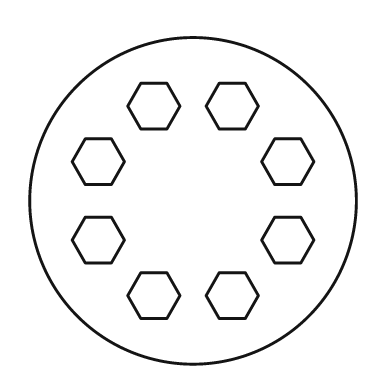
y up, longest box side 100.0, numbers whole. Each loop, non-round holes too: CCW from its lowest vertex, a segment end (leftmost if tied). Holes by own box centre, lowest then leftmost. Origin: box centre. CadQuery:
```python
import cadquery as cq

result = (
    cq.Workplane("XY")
    .moveTo(0.0, 0.0)
    .circle(50.0)
    .moveTo(-16.0, -36.0)
    .lineTo(-8.0, -36.0)
    .lineTo(-4.0, -29.0)
    .lineTo(-8.0, -22.0)
    .lineTo(-16.0, -22.0)
    .lineTo(-20.0, -29.0)
    .close()
    .moveTo(8.0, -36.0)
    .lineTo(16.0, -36.0)
    .lineTo(20.0, -29.0)
    .lineTo(16.0, -22.0)
    .lineTo(8.0, -22.0)
    .lineTo(4.0, -29.0)
    .close()
    .moveTo(-33.0, -19.0)
    .lineTo(-25.0, -19.0)
    .lineTo(-21.0, -12.0)
    .lineTo(-25.0, -5.0)
    .lineTo(-33.0, -5.0)
    .lineTo(-37.0, -12.0)
    .close()
    .moveTo(25.0, -19.0)
    .lineTo(33.0, -19.0)
    .lineTo(37.0, -12.0)
    .lineTo(33.0, -5.0)
    .lineTo(25.0, -5.0)
    .lineTo(21.0, -12.0)
    .close()
    .moveTo(-33.0, 5.0)
    .lineTo(-25.0, 5.0)
    .lineTo(-21.0, 12.0)
    .lineTo(-25.0, 19.0)
    .lineTo(-33.0, 19.0)
    .lineTo(-37.0, 12.0)
    .close()
    .moveTo(25.0, 5.0)
    .lineTo(33.0, 5.0)
    .lineTo(37.0, 12.0)
    .lineTo(33.0, 19.0)
    .lineTo(25.0, 19.0)
    .lineTo(21.0, 12.0)
    .close()
    .moveTo(-16.0, 22.0)
    .lineTo(-8.0, 22.0)
    .lineTo(-4.0, 29.0)
    .lineTo(-8.0, 36.0)
    .lineTo(-16.0, 36.0)
    .lineTo(-20.0, 29.0)
    .close()
    .moveTo(8.0, 22.0)
    .lineTo(16.0, 22.0)
    .lineTo(20.0, 29.0)
    .lineTo(16.0, 36.0)
    .lineTo(8.0, 36.0)
    .lineTo(4.0, 29.0)
    .close()
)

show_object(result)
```